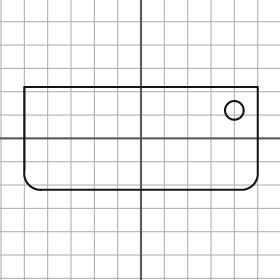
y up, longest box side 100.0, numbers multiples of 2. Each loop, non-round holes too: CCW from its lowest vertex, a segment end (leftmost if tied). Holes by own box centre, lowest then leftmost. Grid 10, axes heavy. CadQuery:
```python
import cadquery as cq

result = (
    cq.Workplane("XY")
    .moveTo(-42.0, -22.0)
    .lineTo(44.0, -22.0)
    .threePointArc((48.0, -20.0), (50.0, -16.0))
    .lineTo(50.0, 22.0)
    .lineTo(-50.0, 22.0)
    .lineTo(-50.0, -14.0)
    .threePointArc((-48.0, -20.0), (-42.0, -22.0))
    .close()
    .moveTo(40.0, 12.0)
    .circle(4.0)
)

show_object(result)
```